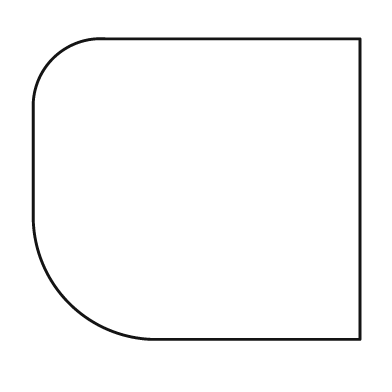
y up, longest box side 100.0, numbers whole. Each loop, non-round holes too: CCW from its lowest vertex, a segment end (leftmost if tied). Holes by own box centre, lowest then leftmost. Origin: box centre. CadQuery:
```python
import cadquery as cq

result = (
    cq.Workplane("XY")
    .moveTo(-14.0, -46.0)
    .lineTo(50.0, -46.0)
    .lineTo(50.0, 46.0)
    .lineTo(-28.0, 46.0)
    .threePointArc((-44.0, 40.0), (-50.0, 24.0))
    .lineTo(-50.0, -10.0)
    .threePointArc((-39.0, -35.0), (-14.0, -46.0))
    .close()
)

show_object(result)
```